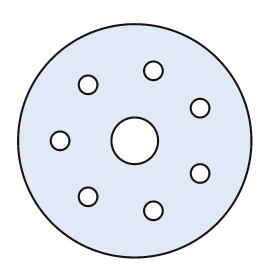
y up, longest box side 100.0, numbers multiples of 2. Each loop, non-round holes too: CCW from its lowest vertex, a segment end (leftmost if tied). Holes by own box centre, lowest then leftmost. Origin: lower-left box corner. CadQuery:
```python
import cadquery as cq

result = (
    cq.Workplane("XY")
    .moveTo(50.0, 50.0)
    .circle(50.0)
    .moveTo(58.0, 20.0)
    .circle(4.0)
    .moveTo(30.0, 26.0)
    .circle(4.0)
    .moveTo(78.0, 36.0)
    .circle(4.0)
    .moveTo(18.0, 50.0)
    .circle(4.0)
    .moveTo(50.0, 50.0)
    .circle(10.0)
    .moveTo(78.0, 64.0)
    .circle(4.0)
    .moveTo(30.0, 74.0)
    .circle(4.0)
    .moveTo(58.0, 80.0)
    .circle(4.0)
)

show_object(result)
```